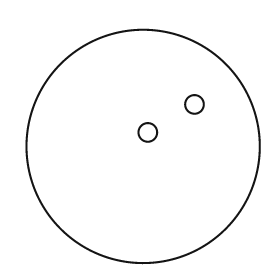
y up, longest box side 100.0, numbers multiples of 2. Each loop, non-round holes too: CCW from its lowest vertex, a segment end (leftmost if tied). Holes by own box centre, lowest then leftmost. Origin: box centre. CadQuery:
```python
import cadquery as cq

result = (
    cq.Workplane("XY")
    .moveTo(0.0, 0.0)
    .circle(50.0)
    .moveTo(2.0, 6.0)
    .circle(4.0)
    .moveTo(22.0, 18.0)
    .circle(4.0)
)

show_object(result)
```